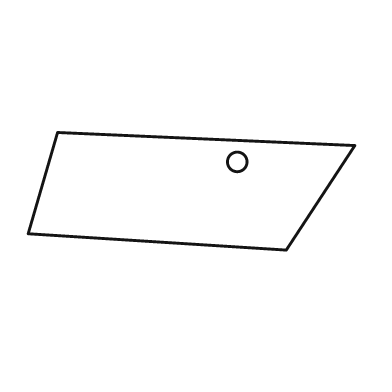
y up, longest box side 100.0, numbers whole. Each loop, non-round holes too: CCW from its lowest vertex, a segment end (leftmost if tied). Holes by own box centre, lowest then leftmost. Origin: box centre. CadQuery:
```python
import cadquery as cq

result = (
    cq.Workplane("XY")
    .moveTo(29.0, -18.0)
    .lineTo(50.0, 14.0)
    .lineTo(-41.0, 18.0)
    .lineTo(-50.0, -13.0)
    .close()
    .moveTo(14.0, 9.0)
    .circle(3.0)
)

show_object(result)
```